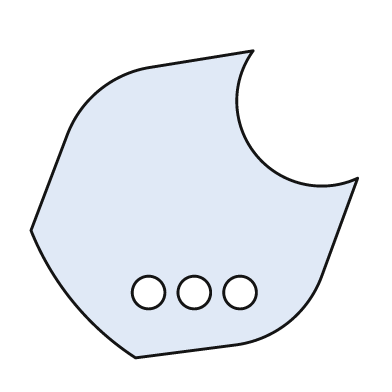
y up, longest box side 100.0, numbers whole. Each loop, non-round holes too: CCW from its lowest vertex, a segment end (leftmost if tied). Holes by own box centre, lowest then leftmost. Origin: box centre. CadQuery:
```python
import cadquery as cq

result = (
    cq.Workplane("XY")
    .moveTo(-18.0, -47.0)
    .lineTo(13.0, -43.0)
    .threePointArc((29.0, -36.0), (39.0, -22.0))
    .lineTo(50.0, 8.0)
    .threePointArc((19.0, 15.0), (18.0, 47.0))
    .lineTo(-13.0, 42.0)
    .threePointArc((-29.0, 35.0), (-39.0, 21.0))
    .lineTo(-50.0, -8.0)
    .threePointArc((-37.0, -30.0), (-18.0, -47.0))
    .close()
    .moveTo(-14.0, -27.0)
    .circle(5.0)
    .moveTo(0.0, -27.0)
    .circle(5.0)
    .moveTo(14.0, -27.0)
    .circle(5.0)
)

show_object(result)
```